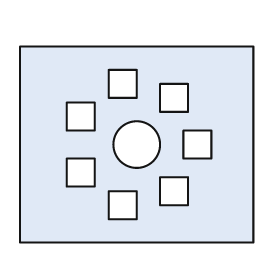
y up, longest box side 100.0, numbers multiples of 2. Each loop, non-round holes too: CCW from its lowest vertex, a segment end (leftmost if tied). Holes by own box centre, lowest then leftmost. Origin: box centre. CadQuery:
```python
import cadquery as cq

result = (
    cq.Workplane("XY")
    .moveTo(-50.0, -42.0)
    .lineTo(50.0, -42.0)
    .lineTo(50.0, 42.0)
    .lineTo(-50.0, 42.0)
    .close()
    .moveTo(-12.0, -32.0)
    .lineTo(0.0, -32.0)
    .lineTo(0.0, -20.0)
    .lineTo(-12.0, -20.0)
    .close()
    .moveTo(10.0, -26.0)
    .lineTo(22.0, -26.0)
    .lineTo(22.0, -14.0)
    .lineTo(10.0, -14.0)
    .close()
    .moveTo(-30.0, -18.0)
    .lineTo(-18.0, -18.0)
    .lineTo(-18.0, -6.0)
    .lineTo(-30.0, -6.0)
    .close()
    .moveTo(0.0, 0.0)
    .circle(10.0)
    .moveTo(20.0, -6.0)
    .lineTo(32.0, -6.0)
    .lineTo(32.0, 6.0)
    .lineTo(20.0, 6.0)
    .close()
    .moveTo(-30.0, 6.0)
    .lineTo(-18.0, 6.0)
    .lineTo(-18.0, 18.0)
    .lineTo(-30.0, 18.0)
    .close()
    .moveTo(10.0, 14.0)
    .lineTo(22.0, 14.0)
    .lineTo(22.0, 26.0)
    .lineTo(10.0, 26.0)
    .close()
    .moveTo(-12.0, 20.0)
    .lineTo(0.0, 20.0)
    .lineTo(0.0, 32.0)
    .lineTo(-12.0, 32.0)
    .close()
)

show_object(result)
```